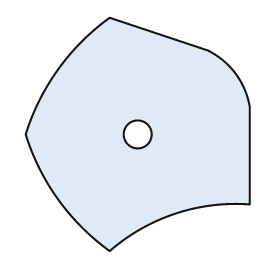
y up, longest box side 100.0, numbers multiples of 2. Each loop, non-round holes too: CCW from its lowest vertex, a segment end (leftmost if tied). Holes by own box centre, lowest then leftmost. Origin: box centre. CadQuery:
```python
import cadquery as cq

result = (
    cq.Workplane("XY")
    .moveTo(-12.0, -50.0)
    .threePointArc((16.0, -34.0), (48.0, -30.0))
    .lineTo(48.0, 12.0)
    .threePointArc((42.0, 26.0), (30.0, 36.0))
    .lineTo(-12.0, 50.0)
    .threePointArc((-34.0, 28.0), (-48.0, 0.0))
    .threePointArc((-34.0, -28.0), (-12.0, -50.0))
    .close()
    .moveTo(0.0, 0.0)
    .circle(6.0)
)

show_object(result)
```